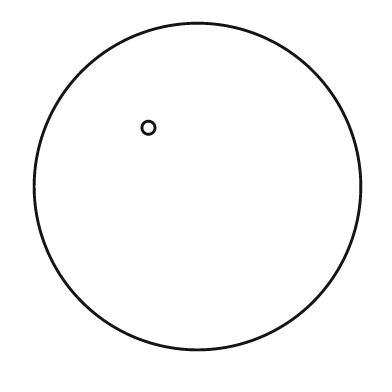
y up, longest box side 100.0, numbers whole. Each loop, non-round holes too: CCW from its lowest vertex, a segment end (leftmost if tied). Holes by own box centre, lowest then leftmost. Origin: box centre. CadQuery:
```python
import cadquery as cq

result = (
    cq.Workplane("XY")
    .moveTo(0.0, 0.0)
    .circle(50.0)
    .moveTo(-15.0, 18.0)
    .circle(2.0)
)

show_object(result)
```